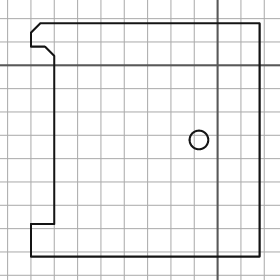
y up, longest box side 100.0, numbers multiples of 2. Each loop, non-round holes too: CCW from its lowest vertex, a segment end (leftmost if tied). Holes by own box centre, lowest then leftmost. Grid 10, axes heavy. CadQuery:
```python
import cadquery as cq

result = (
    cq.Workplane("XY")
    .moveTo(-80.0, -82.0)
    .lineTo(18.0, -82.0)
    .lineTo(18.0, 18.0)
    .lineTo(-76.0, 18.0)
    .lineTo(-80.0, 14.0)
    .lineTo(-80.0, 8.0)
    .lineTo(-74.0, 8.0)
    .lineTo(-70.0, 4.0)
    .lineTo(-70.0, -68.0)
    .lineTo(-80.0, -68.0)
    .close()
    .moveTo(-8.0, -32.0)
    .circle(4.0)
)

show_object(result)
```